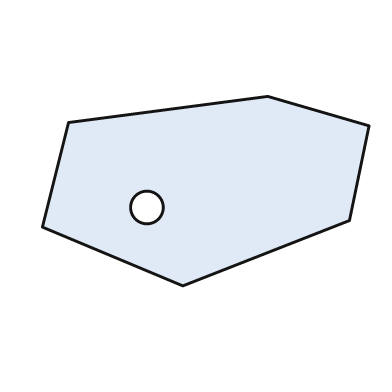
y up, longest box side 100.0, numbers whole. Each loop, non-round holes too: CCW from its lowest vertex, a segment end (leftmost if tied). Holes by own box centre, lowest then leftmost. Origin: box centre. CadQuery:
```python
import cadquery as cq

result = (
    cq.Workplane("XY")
    .moveTo(-7.0, -29.0)
    .lineTo(44.0, -9.0)
    .lineTo(50.0, 20.0)
    .lineTo(19.0, 29.0)
    .lineTo(-42.0, 21.0)
    .lineTo(-50.0, -11.0)
    .close()
    .moveTo(-18.0, -5.0)
    .circle(5.0)
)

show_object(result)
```